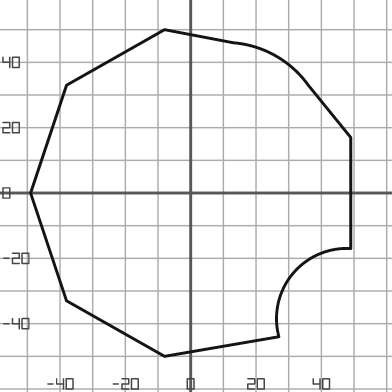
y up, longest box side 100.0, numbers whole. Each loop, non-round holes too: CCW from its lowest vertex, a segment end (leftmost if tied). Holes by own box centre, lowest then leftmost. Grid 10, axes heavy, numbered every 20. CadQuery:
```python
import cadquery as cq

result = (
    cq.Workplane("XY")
    .moveTo(-8.0, -50.0)
    .lineTo(27.0, -44.0)
    .threePointArc((31.0, -25.0), (49.0, -17.0))
    .lineTo(49.0, 17.0)
    .lineTo(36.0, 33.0)
    .threePointArc((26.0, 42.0), (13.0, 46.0))
    .lineTo(-8.0, 50.0)
    .lineTo(-38.0, 33.0)
    .lineTo(-49.0, 0.0)
    .lineTo(-38.0, -33.0)
    .close()
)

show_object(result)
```